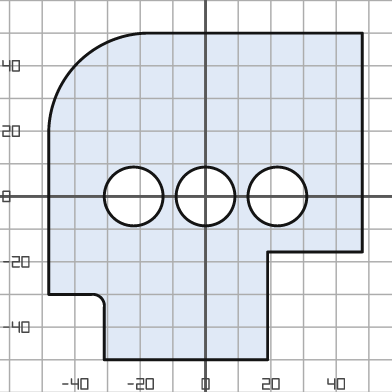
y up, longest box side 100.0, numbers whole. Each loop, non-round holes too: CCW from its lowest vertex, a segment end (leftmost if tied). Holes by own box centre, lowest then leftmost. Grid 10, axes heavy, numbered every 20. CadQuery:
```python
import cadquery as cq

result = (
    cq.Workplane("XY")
    .moveTo(-31.0, -50.0)
    .lineTo(19.0, -50.0)
    .lineTo(19.0, -17.0)
    .lineTo(48.0, -17.0)
    .lineTo(48.0, 50.0)
    .lineTo(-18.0, 50.0)
    .threePointArc((-39.0, 41.0), (-48.0, 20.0))
    .lineTo(-48.0, -30.0)
    .lineTo(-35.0, -30.0)
    .threePointArc((-32.0, -31.0), (-31.0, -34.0))
    .close()
    .moveTo(-22.0, 0.0)
    .circle(9.0)
    .moveTo(0.0, 0.0)
    .circle(9.0)
    .moveTo(22.0, 0.0)
    .circle(9.0)
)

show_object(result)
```